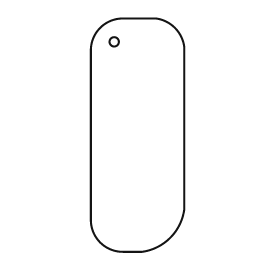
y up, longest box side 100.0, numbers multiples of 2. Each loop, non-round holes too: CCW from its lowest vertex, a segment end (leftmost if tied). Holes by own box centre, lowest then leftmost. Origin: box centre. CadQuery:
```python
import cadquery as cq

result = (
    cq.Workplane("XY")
    .moveTo(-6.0, -50.0)
    .lineTo(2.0, -50.0)
    .threePointArc((14.0, -44.0), (20.0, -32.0))
    .lineTo(20.0, 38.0)
    .threePointArc((16.0, 46.0), (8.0, 50.0))
    .lineTo(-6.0, 50.0)
    .threePointArc((-16.0, 46.0), (-20.0, 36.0))
    .lineTo(-20.0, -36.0)
    .threePointArc((-16.0, -46.0), (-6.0, -50.0))
    .close()
    .moveTo(-10.0, 40.0)
    .circle(2.0)
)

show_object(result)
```